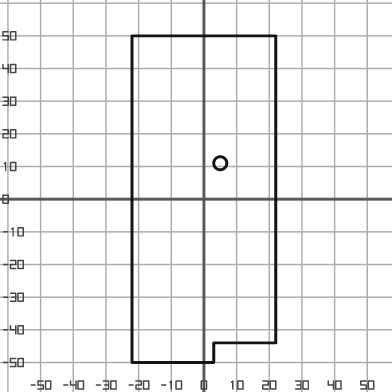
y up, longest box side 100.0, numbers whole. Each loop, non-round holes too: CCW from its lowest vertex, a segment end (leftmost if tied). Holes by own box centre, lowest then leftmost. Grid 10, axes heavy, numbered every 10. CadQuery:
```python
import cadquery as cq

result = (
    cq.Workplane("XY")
    .moveTo(-22.0, -50.0)
    .lineTo(3.0, -50.0)
    .lineTo(3.0, -44.0)
    .lineTo(22.0, -44.0)
    .lineTo(22.0, 50.0)
    .lineTo(-22.0, 50.0)
    .close()
    .moveTo(5.0, 11.0)
    .circle(2.0)
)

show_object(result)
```